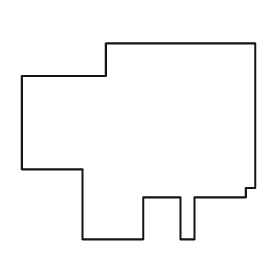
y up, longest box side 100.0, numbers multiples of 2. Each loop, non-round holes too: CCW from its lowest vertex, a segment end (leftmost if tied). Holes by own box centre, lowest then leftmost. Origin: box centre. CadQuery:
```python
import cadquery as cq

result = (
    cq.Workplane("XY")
    .moveTo(-24.0, -42.0)
    .lineTo(2.0, -42.0)
    .lineTo(2.0, -24.0)
    .lineTo(18.0, -24.0)
    .lineTo(18.0, -42.0)
    .lineTo(24.0, -42.0)
    .lineTo(24.0, -24.0)
    .lineTo(46.0, -24.0)
    .lineTo(46.0, -20.0)
    .lineTo(50.0, -20.0)
    .lineTo(50.0, 42.0)
    .lineTo(-14.0, 42.0)
    .lineTo(-14.0, 28.0)
    .lineTo(-50.0, 28.0)
    .lineTo(-50.0, -12.0)
    .lineTo(-24.0, -12.0)
    .close()
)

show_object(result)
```